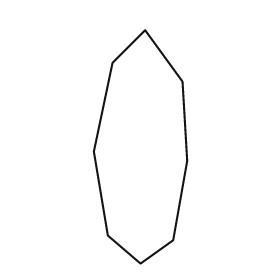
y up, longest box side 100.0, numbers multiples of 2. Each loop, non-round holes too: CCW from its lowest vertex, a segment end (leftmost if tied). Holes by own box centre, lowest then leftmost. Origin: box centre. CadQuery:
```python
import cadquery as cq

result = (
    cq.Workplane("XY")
    .moveTo(0.0, -50.0)
    .lineTo(14.0, -40.0)
    .lineTo(20.0, -6.0)
    .lineTo(18.0, 28.0)
    .lineTo(2.0, 50.0)
    .lineTo(-12.0, 36.0)
    .lineTo(-20.0, -2.0)
    .lineTo(-14.0, -38.0)
    .close()
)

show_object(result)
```